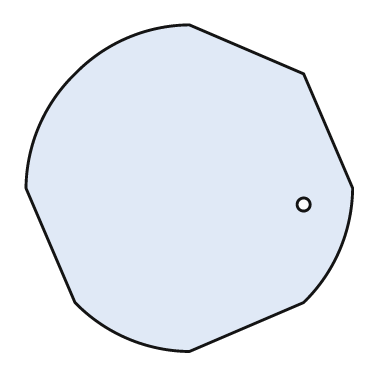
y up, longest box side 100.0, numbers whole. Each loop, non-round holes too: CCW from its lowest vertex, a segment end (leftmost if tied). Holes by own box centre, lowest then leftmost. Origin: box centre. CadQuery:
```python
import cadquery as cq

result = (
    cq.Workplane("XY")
    .moveTo(0.0, -50.0)
    .lineTo(35.0, -35.0)
    .threePointArc((46.0, -19.0), (50.0, 0.0))
    .lineTo(35.0, 35.0)
    .lineTo(0.0, 50.0)
    .threePointArc((-19.0, 46.0), (-35.0, 35.0))
    .threePointArc((-46.0, 19.0), (-50.0, 0.0))
    .lineTo(-35.0, -35.0)
    .threePointArc((-19.0, -46.0), (0.0, -50.0))
    .close()
    .moveTo(35.0, -5.0)
    .circle(2.0)
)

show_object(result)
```